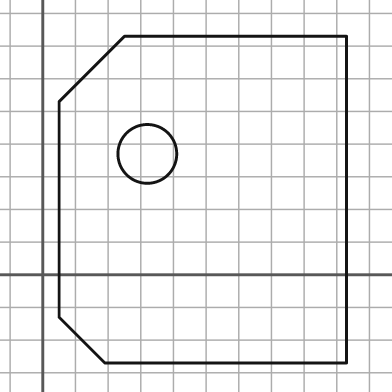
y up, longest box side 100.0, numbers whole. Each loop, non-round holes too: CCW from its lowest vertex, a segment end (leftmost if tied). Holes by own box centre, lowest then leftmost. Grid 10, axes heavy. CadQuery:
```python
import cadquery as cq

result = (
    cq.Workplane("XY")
    .moveTo(19.0, -27.0)
    .lineTo(93.0, -27.0)
    .lineTo(93.0, 73.0)
    .lineTo(25.0, 73.0)
    .lineTo(5.0, 53.0)
    .lineTo(5.0, -13.0)
    .close()
    .moveTo(32.0, 37.0)
    .circle(9.0)
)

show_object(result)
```